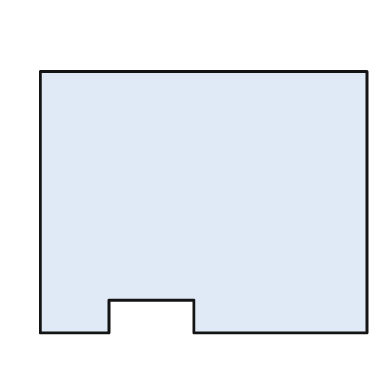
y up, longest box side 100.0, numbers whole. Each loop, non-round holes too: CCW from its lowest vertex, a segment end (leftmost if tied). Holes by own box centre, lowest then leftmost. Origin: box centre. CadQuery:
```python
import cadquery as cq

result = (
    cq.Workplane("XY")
    .moveTo(-50.0, -40.0)
    .lineTo(-29.0, -40.0)
    .lineTo(-29.0, -30.0)
    .lineTo(-3.0, -30.0)
    .lineTo(-3.0, -40.0)
    .lineTo(50.0, -40.0)
    .lineTo(50.0, 40.0)
    .lineTo(-50.0, 40.0)
    .close()
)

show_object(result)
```